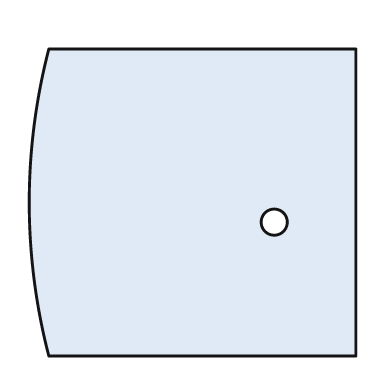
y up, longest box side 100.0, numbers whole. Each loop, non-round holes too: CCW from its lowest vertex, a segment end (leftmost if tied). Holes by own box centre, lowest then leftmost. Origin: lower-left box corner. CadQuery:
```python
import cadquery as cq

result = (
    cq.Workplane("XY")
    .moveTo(6.0, 0.0)
    .lineTo(100.0, 0.0)
    .lineTo(100.0, 94.0)
    .lineTo(6.0, 94.0)
    .threePointArc((0.0, 47.0), (6.0, 0.0))
    .close()
    .moveTo(75.0, 41.0)
    .circle(4.0)
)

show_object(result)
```